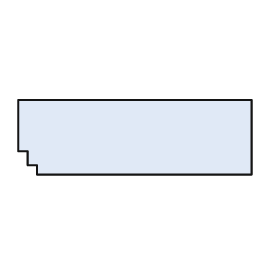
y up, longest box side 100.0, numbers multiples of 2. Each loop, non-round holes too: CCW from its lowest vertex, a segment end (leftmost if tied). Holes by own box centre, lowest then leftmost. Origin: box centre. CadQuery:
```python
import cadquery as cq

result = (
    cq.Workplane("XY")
    .moveTo(-42.0, -16.0)
    .lineTo(50.0, -16.0)
    .lineTo(50.0, 16.0)
    .lineTo(-50.0, 16.0)
    .lineTo(-50.0, -6.0)
    .lineTo(-46.0, -6.0)
    .lineTo(-46.0, -12.0)
    .lineTo(-42.0, -12.0)
    .close()
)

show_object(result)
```